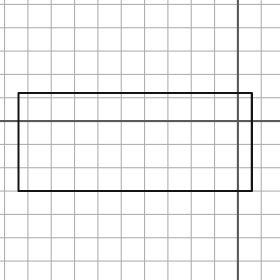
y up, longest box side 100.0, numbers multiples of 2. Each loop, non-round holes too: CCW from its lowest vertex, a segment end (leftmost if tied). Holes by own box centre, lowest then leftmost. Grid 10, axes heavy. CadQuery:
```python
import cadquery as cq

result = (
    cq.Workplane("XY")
    .moveTo(-94.0, -30.0)
    .lineTo(6.0, -30.0)
    .lineTo(6.0, 12.0)
    .lineTo(-94.0, 12.0)
    .close()
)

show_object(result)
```